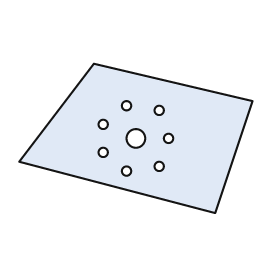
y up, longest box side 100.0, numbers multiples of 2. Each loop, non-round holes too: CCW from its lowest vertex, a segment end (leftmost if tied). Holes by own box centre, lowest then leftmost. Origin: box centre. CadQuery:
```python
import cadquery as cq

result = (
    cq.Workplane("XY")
    .moveTo(34.0, -32.0)
    .lineTo(50.0, 16.0)
    .lineTo(-18.0, 32.0)
    .lineTo(-50.0, -10.0)
    .close()
    .moveTo(-4.0, -14.0)
    .circle(2.0)
    .moveTo(10.0, -12.0)
    .circle(2.0)
    .moveTo(-14.0, -6.0)
    .circle(2.0)
    .moveTo(0.0, 0.0)
    .circle(4.0)
    .moveTo(14.0, 0.0)
    .circle(2.0)
    .moveTo(-14.0, 6.0)
    .circle(2.0)
    .moveTo(10.0, 12.0)
    .circle(2.0)
    .moveTo(-4.0, 14.0)
    .circle(2.0)
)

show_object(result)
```